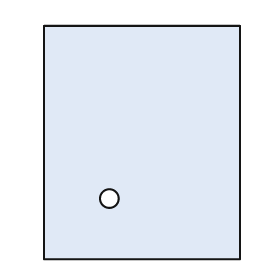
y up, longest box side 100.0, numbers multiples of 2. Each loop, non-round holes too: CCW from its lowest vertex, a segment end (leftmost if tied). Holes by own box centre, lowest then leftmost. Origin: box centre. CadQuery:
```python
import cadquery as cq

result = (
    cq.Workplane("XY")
    .moveTo(-42.0, -50.0)
    .lineTo(42.0, -50.0)
    .lineTo(42.0, 50.0)
    .lineTo(-42.0, 50.0)
    .close()
    .moveTo(-14.0, -24.0)
    .circle(4.0)
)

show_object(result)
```